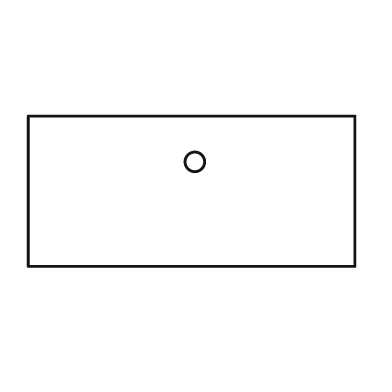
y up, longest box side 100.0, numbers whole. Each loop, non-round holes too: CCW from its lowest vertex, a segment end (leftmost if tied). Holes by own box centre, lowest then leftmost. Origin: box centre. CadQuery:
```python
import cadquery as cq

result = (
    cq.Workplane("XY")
    .moveTo(-50.0, -23.0)
    .lineTo(50.0, -23.0)
    .lineTo(50.0, 23.0)
    .lineTo(-50.0, 23.0)
    .close()
    .moveTo(1.0, 9.0)
    .circle(3.0)
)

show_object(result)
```